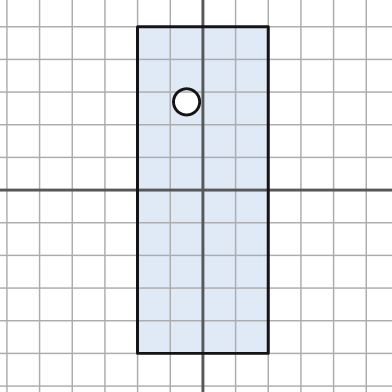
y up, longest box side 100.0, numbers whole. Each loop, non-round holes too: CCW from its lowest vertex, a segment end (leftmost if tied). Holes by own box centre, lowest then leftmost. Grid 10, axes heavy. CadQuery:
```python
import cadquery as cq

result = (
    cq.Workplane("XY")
    .moveTo(-20.0, -50.0)
    .lineTo(20.0, -50.0)
    .lineTo(20.0, 50.0)
    .lineTo(-20.0, 50.0)
    .close()
    .moveTo(-5.0, 27.0)
    .circle(4.0)
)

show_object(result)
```